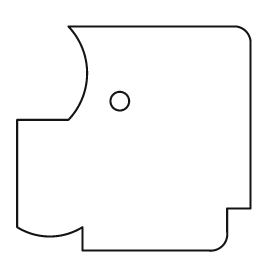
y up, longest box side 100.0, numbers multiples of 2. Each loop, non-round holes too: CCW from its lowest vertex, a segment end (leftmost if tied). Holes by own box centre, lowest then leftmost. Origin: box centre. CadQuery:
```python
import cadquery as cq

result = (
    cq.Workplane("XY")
    .moveTo(-22.0, -48.0)
    .lineTo(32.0, -48.0)
    .threePointArc((38.0, -46.0), (40.0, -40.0))
    .lineTo(40.0, -30.0)
    .lineTo(50.0, -30.0)
    .lineTo(50.0, 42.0)
    .threePointArc((48.0, 46.0), (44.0, 48.0))
    .lineTo(-28.0, 48.0)
    .threePointArc((-20.0, 28.0), (-28.0, 8.0))
    .lineTo(-50.0, 8.0)
    .lineTo(-50.0, -38.0)
    .threePointArc((-36.0, -42.0), (-22.0, -38.0))
    .close()
    .moveTo(-6.0, 16.0)
    .circle(4.0)
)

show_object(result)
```